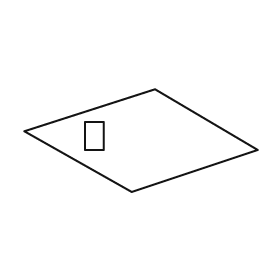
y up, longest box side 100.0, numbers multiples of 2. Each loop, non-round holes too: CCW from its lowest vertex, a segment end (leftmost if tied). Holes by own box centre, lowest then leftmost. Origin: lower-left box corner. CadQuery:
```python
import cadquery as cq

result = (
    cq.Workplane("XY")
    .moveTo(46.0, 0.0)
    .lineTo(100.0, 18.0)
    .lineTo(56.0, 44.0)
    .lineTo(0.0, 26.0)
    .close()
    .moveTo(26.0, 18.0)
    .lineTo(34.0, 18.0)
    .lineTo(34.0, 30.0)
    .lineTo(26.0, 30.0)
    .close()
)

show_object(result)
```